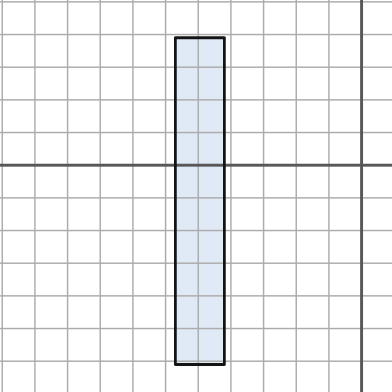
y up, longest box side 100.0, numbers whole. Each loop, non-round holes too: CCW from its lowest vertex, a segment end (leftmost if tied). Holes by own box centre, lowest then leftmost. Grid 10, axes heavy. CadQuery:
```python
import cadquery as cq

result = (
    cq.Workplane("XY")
    .moveTo(-57.0, -61.0)
    .lineTo(-42.0, -61.0)
    .lineTo(-42.0, 39.0)
    .lineTo(-57.0, 39.0)
    .close()
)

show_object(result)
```